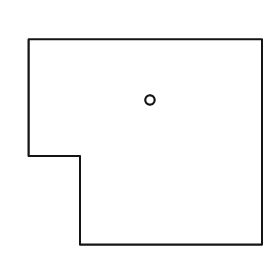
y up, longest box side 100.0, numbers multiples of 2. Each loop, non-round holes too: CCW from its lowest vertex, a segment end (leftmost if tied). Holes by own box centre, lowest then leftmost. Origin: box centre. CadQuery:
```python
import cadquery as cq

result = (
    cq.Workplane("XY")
    .moveTo(-28.0, -44.0)
    .lineTo(50.0, -44.0)
    .lineTo(50.0, 44.0)
    .lineTo(-50.0, 44.0)
    .lineTo(-50.0, -6.0)
    .lineTo(-28.0, -6.0)
    .close()
    .moveTo(2.0, 18.0)
    .circle(2.0)
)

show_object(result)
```